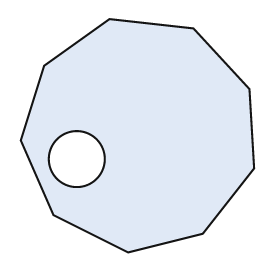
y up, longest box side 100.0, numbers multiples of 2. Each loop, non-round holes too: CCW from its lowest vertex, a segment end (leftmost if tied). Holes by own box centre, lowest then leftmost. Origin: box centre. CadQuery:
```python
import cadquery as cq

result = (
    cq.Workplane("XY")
    .moveTo(-4.0, -50.0)
    .lineTo(28.0, -42.0)
    .lineTo(50.0, -14.0)
    .lineTo(48.0, 20.0)
    .lineTo(24.0, 46.0)
    .lineTo(-12.0, 50.0)
    .lineTo(-40.0, 30.0)
    .lineTo(-50.0, -2.0)
    .lineTo(-36.0, -34.0)
    .close()
    .moveTo(-26.0, -10.0)
    .circle(12.0)
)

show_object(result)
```